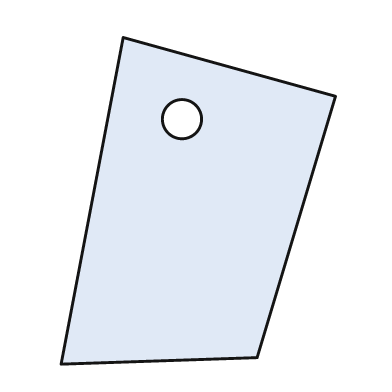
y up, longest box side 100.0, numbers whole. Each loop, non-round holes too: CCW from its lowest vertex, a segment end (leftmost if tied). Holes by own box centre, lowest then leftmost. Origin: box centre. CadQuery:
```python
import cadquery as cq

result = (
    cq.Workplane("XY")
    .moveTo(-42.0, -50.0)
    .lineTo(18.0, -48.0)
    .lineTo(42.0, 32.0)
    .lineTo(-23.0, 50.0)
    .close()
    .moveTo(-5.0, 25.0)
    .circle(6.0)
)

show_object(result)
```